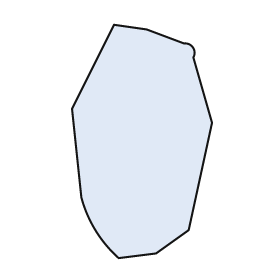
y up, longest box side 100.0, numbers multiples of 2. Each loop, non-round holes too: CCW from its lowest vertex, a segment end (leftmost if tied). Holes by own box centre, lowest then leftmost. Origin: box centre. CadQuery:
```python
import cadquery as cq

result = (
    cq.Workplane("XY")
    .moveTo(-10.0, -50.0)
    .lineTo(6.0, -48.0)
    .lineTo(20.0, -38.0)
    .lineTo(30.0, 8.0)
    .lineTo(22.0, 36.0)
    .threePointArc((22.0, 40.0), (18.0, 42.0))
    .lineTo(2.0, 48.0)
    .lineTo(-12.0, 50.0)
    .lineTo(-30.0, 14.0)
    .lineTo(-26.0, -24.0)
    .threePointArc((-20.0, -38.0), (-10.0, -50.0))
    .close()
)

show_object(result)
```